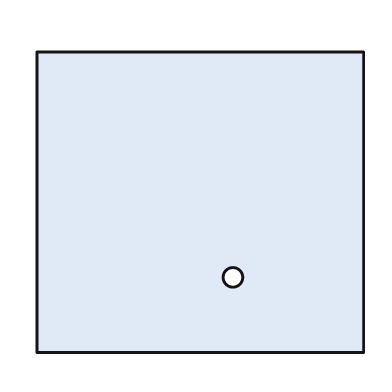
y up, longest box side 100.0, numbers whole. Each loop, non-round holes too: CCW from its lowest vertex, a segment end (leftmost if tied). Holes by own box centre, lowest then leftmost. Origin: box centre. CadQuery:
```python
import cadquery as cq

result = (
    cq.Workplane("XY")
    .moveTo(-50.0, -46.0)
    .lineTo(50.0, -46.0)
    .lineTo(50.0, 46.0)
    .lineTo(-50.0, 46.0)
    .close()
    .moveTo(10.0, -23.0)
    .circle(3.0)
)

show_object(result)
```